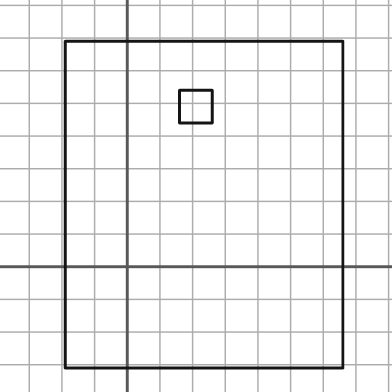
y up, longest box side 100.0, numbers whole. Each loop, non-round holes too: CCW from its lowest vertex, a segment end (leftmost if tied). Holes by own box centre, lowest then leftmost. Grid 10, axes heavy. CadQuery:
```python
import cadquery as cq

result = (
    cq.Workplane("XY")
    .moveTo(-19.0, -31.0)
    .lineTo(66.0, -31.0)
    .lineTo(66.0, 69.0)
    .lineTo(-19.0, 69.0)
    .close()
    .moveTo(16.0, 44.0)
    .lineTo(26.0, 44.0)
    .lineTo(26.0, 54.0)
    .lineTo(16.0, 54.0)
    .close()
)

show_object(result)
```